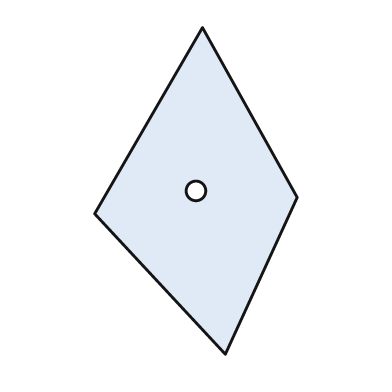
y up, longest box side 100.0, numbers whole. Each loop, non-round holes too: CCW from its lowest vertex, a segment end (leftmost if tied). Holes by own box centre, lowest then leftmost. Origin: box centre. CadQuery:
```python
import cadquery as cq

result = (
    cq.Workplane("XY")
    .moveTo(9.0, -50.0)
    .lineTo(31.0, -2.0)
    .lineTo(2.0, 50.0)
    .lineTo(-31.0, -7.0)
    .close()
    .moveTo(0.0, 0.0)
    .circle(3.0)
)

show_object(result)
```